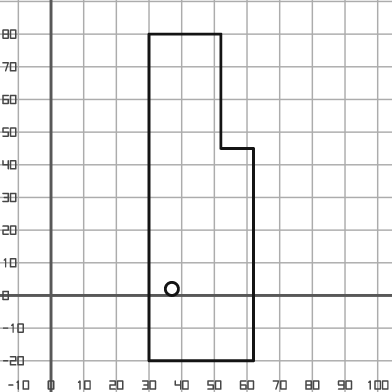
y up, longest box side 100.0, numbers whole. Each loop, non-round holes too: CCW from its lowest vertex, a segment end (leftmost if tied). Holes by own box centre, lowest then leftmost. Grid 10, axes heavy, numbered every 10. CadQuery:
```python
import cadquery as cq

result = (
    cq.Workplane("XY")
    .moveTo(30.0, -20.0)
    .lineTo(62.0, -20.0)
    .lineTo(62.0, 45.0)
    .lineTo(52.0, 45.0)
    .lineTo(52.0, 80.0)
    .lineTo(30.0, 80.0)
    .close()
    .moveTo(37.0, 2.0)
    .circle(2.0)
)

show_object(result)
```